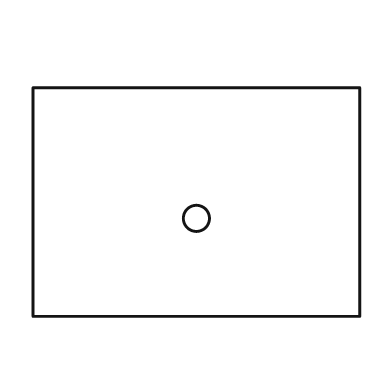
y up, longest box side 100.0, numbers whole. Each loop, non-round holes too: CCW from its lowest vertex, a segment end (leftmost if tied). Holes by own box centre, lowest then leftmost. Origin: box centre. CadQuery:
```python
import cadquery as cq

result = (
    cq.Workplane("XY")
    .moveTo(-50.0, -35.0)
    .lineTo(50.0, -35.0)
    .lineTo(50.0, 35.0)
    .lineTo(-50.0, 35.0)
    .close()
    .moveTo(0.0, -5.0)
    .circle(4.0)
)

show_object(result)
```